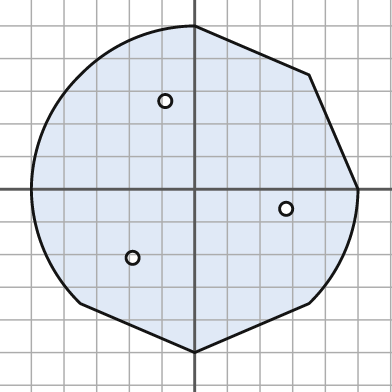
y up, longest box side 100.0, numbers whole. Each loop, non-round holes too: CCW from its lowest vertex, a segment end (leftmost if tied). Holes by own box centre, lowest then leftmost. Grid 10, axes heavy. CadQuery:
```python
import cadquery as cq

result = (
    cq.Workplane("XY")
    .moveTo(0.0, -50.0)
    .lineTo(35.0, -35.0)
    .threePointArc((46.0, -19.0), (50.0, 0.0))
    .lineTo(35.0, 35.0)
    .lineTo(0.0, 50.0)
    .threePointArc((-19.0, 46.0), (-35.0, 35.0))
    .threePointArc((-46.0, 19.0), (-50.0, 0.0))
    .threePointArc((-46.0, -19.0), (-35.0, -35.0))
    .close()
    .moveTo(-19.0, -21.0)
    .circle(2.0)
    .moveTo(28.0, -6.0)
    .circle(2.0)
    .moveTo(-9.0, 27.0)
    .circle(2.0)
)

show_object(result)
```